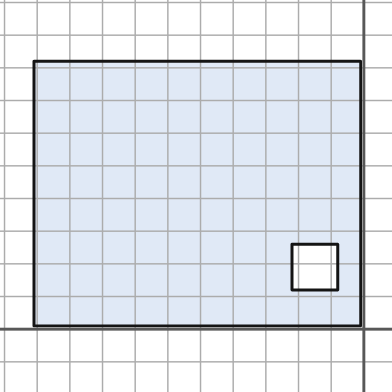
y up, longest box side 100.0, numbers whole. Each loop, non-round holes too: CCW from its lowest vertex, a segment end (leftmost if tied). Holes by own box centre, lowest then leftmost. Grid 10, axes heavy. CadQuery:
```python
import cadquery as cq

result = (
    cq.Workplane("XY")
    .moveTo(-101.0, 1.0)
    .lineTo(-1.0, 1.0)
    .lineTo(-1.0, 82.0)
    .lineTo(-101.0, 82.0)
    .close()
    .moveTo(-22.0, 12.0)
    .lineTo(-8.0, 12.0)
    .lineTo(-8.0, 26.0)
    .lineTo(-22.0, 26.0)
    .close()
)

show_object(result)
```